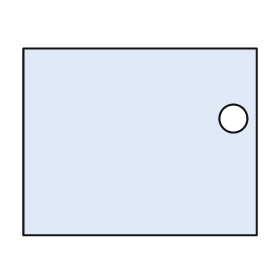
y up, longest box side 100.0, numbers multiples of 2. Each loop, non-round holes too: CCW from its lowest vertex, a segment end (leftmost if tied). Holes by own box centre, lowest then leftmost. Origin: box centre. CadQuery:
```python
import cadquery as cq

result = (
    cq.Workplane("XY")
    .moveTo(-50.0, -40.0)
    .lineTo(50.0, -40.0)
    .lineTo(50.0, 40.0)
    .lineTo(-50.0, 40.0)
    .close()
    .moveTo(40.0, 10.0)
    .circle(6.0)
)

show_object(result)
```